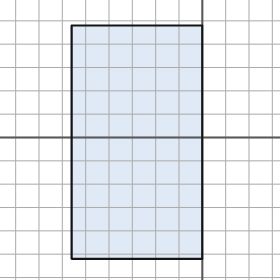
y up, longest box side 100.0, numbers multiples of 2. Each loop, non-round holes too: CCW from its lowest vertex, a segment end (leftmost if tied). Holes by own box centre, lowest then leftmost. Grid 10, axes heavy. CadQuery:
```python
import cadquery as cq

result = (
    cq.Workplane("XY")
    .moveTo(-56.0, -52.0)
    .lineTo(0.0, -52.0)
    .lineTo(0.0, 48.0)
    .lineTo(-56.0, 48.0)
    .close()
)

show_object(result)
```